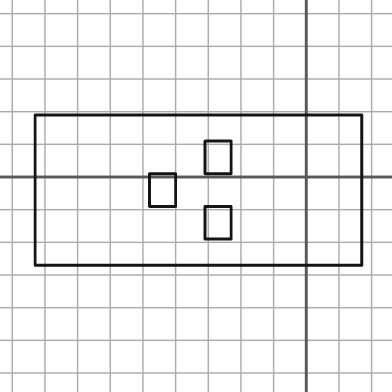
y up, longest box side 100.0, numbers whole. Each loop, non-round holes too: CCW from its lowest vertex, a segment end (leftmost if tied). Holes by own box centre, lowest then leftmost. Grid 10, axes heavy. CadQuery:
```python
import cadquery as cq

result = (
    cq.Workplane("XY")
    .moveTo(-83.0, -27.0)
    .lineTo(17.0, -27.0)
    .lineTo(17.0, 19.0)
    .lineTo(-83.0, 19.0)
    .close()
    .moveTo(-31.0, -19.0)
    .lineTo(-23.0, -19.0)
    .lineTo(-23.0, -9.0)
    .lineTo(-31.0, -9.0)
    .close()
    .moveTo(-48.0, -9.0)
    .lineTo(-40.0, -9.0)
    .lineTo(-40.0, 1.0)
    .lineTo(-48.0, 1.0)
    .close()
    .moveTo(-31.0, 1.0)
    .lineTo(-23.0, 1.0)
    .lineTo(-23.0, 11.0)
    .lineTo(-31.0, 11.0)
    .close()
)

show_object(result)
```